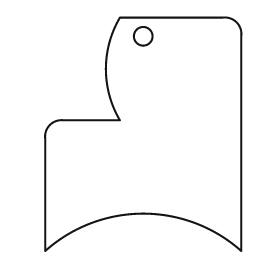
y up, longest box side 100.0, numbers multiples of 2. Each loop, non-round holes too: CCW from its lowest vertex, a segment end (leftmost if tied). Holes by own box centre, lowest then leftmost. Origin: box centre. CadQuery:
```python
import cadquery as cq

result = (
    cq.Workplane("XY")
    .moveTo(-42.0, -50.0)
    .threePointArc((0.0, -34.0), (42.0, -50.0))
    .lineTo(42.0, 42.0)
    .threePointArc((40.0, 48.0), (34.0, 50.0))
    .lineTo(-10.0, 50.0)
    .threePointArc((-16.0, 28.0), (-10.0, 6.0))
    .lineTo(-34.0, 6.0)
    .threePointArc((-40.0, 4.0), (-42.0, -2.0))
    .close()
    .moveTo(0.0, 42.0)
    .circle(4.0)
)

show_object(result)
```